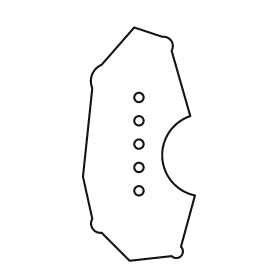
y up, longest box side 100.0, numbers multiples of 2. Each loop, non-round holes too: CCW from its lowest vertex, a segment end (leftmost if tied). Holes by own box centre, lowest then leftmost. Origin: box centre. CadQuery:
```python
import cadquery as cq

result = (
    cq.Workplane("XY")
    .moveTo(-4.0, -50.0)
    .lineTo(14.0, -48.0)
    .threePointArc((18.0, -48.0), (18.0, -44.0))
    .lineTo(24.0, -22.0)
    .threePointArc((10.0, -6.0), (22.0, 12.0))
    .lineTo(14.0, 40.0)
    .threePointArc((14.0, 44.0), (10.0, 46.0))
    .lineTo(-2.0, 50.0)
    .lineTo(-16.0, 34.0)
    .threePointArc((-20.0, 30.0), (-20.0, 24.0))
    .lineTo(-24.0, -14.0)
    .lineTo(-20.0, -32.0)
    .threePointArc((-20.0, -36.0), (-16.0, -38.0))
    .close()
    .moveTo(0.0, -20.0)
    .circle(2.0)
    .moveTo(0.0, -10.0)
    .circle(2.0)
    .moveTo(0.0, 0.0)
    .circle(2.0)
    .moveTo(0.0, 10.0)
    .circle(2.0)
    .moveTo(0.0, 20.0)
    .circle(2.0)
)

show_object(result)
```